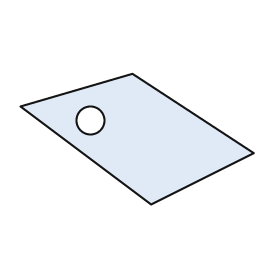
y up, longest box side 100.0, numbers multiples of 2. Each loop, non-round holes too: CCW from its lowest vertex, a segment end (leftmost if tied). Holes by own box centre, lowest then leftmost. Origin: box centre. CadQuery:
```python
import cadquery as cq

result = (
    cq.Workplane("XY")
    .moveTo(6.0, -28.0)
    .lineTo(50.0, -6.0)
    .lineTo(-2.0, 28.0)
    .lineTo(-50.0, 14.0)
    .close()
    .moveTo(-20.0, 8.0)
    .circle(6.0)
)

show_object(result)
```